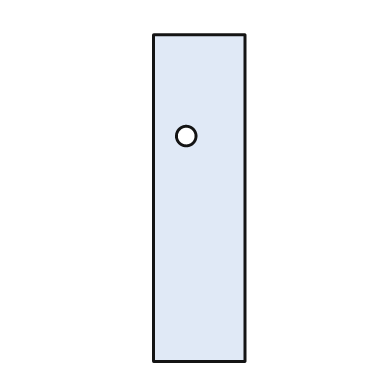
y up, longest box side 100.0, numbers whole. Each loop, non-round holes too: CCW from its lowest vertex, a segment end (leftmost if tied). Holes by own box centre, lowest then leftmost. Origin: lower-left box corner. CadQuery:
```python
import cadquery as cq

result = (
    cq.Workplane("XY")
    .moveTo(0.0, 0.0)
    .lineTo(28.0, 0.0)
    .lineTo(28.0, 100.0)
    .lineTo(0.0, 100.0)
    .close()
    .moveTo(10.0, 69.0)
    .circle(3.0)
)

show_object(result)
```